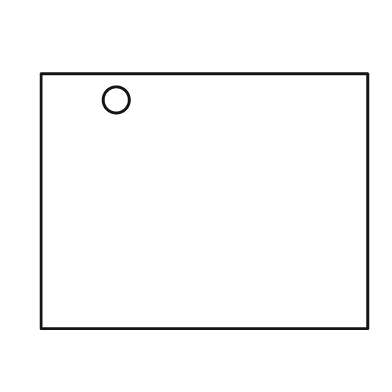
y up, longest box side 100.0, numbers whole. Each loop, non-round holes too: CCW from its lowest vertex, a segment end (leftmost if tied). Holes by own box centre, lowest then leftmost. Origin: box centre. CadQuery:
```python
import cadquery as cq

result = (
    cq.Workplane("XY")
    .moveTo(-50.0, -39.0)
    .lineTo(50.0, -39.0)
    .lineTo(50.0, 39.0)
    .lineTo(-50.0, 39.0)
    .close()
    .moveTo(-27.0, 31.0)
    .circle(4.0)
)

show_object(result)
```